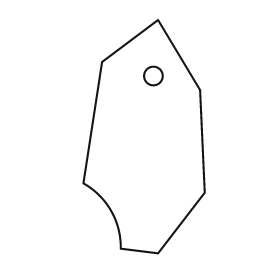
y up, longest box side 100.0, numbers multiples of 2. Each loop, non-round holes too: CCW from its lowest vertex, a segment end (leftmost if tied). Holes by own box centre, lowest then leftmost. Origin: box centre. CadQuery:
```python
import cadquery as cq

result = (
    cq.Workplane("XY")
    .moveTo(6.0, -50.0)
    .lineTo(26.0, -24.0)
    .lineTo(24.0, 20.0)
    .lineTo(6.0, 50.0)
    .lineTo(-18.0, 32.0)
    .lineTo(-26.0, -20.0)
    .threePointArc((-14.0, -32.0), (-10.0, -48.0))
    .close()
    .moveTo(4.0, 26.0)
    .circle(4.0)
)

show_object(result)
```